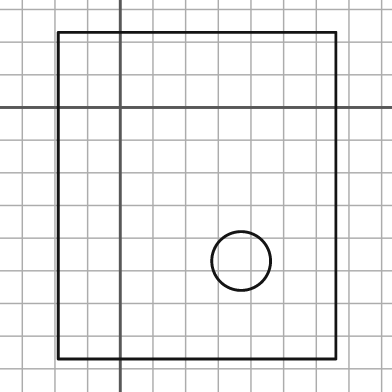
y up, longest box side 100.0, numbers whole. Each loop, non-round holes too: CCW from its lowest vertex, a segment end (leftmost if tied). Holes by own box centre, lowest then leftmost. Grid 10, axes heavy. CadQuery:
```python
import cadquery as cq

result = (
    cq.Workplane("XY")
    .moveTo(-19.0, -77.0)
    .lineTo(66.0, -77.0)
    .lineTo(66.0, 23.0)
    .lineTo(-19.0, 23.0)
    .close()
    .moveTo(37.0, -47.0)
    .circle(9.0)
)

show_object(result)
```